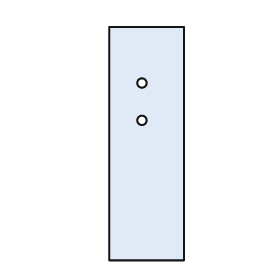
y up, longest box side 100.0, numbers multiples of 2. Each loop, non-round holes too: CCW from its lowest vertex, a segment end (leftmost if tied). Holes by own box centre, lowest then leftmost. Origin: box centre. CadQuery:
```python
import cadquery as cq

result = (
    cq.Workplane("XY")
    .moveTo(-16.0, -50.0)
    .lineTo(16.0, -50.0)
    .lineTo(16.0, 50.0)
    .lineTo(-16.0, 50.0)
    .close()
    .moveTo(-2.0, 10.0)
    .circle(2.0)
    .moveTo(-2.0, 26.0)
    .circle(2.0)
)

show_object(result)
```